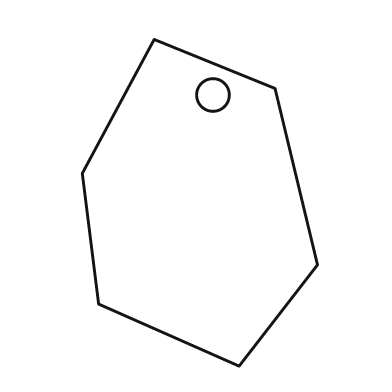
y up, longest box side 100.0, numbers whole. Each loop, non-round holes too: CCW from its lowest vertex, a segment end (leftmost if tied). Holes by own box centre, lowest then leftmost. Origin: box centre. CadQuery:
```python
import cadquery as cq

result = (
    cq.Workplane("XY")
    .moveTo(12.0, -50.0)
    .lineTo(36.0, -19.0)
    .lineTo(23.0, 35.0)
    .lineTo(-14.0, 50.0)
    .lineTo(-36.0, 9.0)
    .lineTo(-31.0, -31.0)
    .close()
    .moveTo(4.0, 33.0)
    .circle(5.0)
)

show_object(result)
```